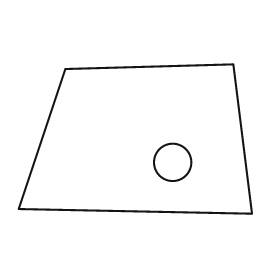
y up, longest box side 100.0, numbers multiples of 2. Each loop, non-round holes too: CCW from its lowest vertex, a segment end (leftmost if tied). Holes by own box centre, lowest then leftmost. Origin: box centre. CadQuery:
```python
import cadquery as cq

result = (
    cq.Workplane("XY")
    .moveTo(50.0, -32.0)
    .lineTo(42.0, 32.0)
    .lineTo(-30.0, 30.0)
    .lineTo(-50.0, -30.0)
    .close()
    .moveTo(16.0, -10.0)
    .circle(8.0)
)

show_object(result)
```